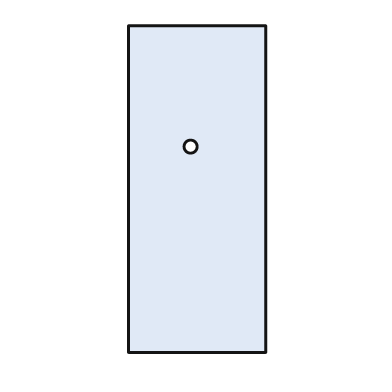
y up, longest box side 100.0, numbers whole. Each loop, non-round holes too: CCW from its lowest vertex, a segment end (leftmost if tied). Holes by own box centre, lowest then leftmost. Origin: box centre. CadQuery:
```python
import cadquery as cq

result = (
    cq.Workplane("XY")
    .moveTo(-21.0, -50.0)
    .lineTo(21.0, -50.0)
    .lineTo(21.0, 50.0)
    .lineTo(-21.0, 50.0)
    .close()
    .moveTo(-2.0, 13.0)
    .circle(2.0)
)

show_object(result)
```